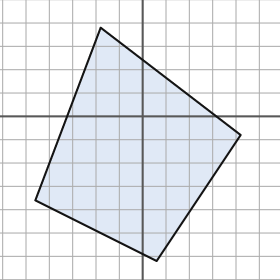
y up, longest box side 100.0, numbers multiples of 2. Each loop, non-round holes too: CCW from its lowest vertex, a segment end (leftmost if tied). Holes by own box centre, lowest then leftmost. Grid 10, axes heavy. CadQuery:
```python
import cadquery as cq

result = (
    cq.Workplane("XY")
    .moveTo(6.0, -62.0)
    .lineTo(42.0, -8.0)
    .lineTo(-18.0, 38.0)
    .lineTo(-46.0, -36.0)
    .close()
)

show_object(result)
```